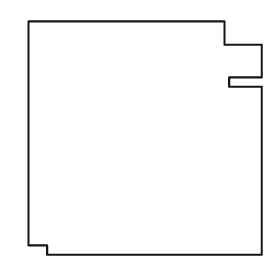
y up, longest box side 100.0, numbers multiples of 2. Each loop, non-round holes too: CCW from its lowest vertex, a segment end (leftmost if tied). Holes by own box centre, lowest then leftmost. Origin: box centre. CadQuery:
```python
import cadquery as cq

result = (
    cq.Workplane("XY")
    .moveTo(-42.0, -50.0)
    .lineTo(50.0, -50.0)
    .lineTo(50.0, 22.0)
    .lineTo(36.0, 22.0)
    .lineTo(36.0, 26.0)
    .lineTo(50.0, 26.0)
    .lineTo(50.0, 40.0)
    .lineTo(34.0, 40.0)
    .lineTo(34.0, 50.0)
    .lineTo(-50.0, 50.0)
    .lineTo(-50.0, -46.0)
    .lineTo(-42.0, -46.0)
    .close()
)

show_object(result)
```